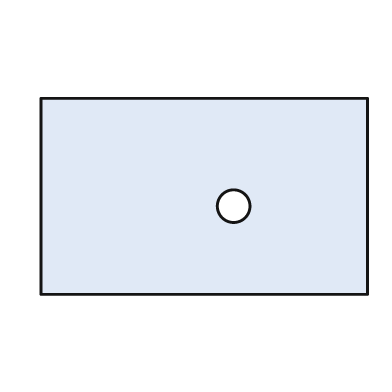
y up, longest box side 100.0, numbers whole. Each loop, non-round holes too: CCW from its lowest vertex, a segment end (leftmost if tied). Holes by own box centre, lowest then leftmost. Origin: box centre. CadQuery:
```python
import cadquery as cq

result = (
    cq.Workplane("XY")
    .moveTo(-50.0, -30.0)
    .lineTo(50.0, -30.0)
    .lineTo(50.0, 30.0)
    .lineTo(-50.0, 30.0)
    .close()
    .moveTo(9.0, -3.0)
    .circle(5.0)
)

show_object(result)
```